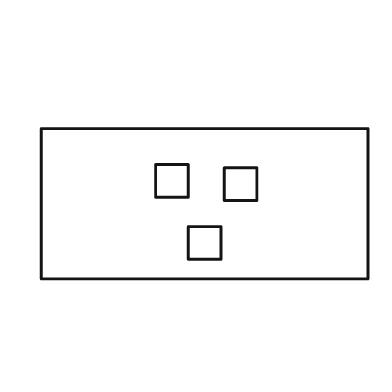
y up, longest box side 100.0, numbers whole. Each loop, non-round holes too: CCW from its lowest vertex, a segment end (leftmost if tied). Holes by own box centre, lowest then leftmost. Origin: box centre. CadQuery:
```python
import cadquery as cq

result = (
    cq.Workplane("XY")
    .moveTo(-50.0, -23.0)
    .lineTo(50.0, -23.0)
    .lineTo(50.0, 23.0)
    .lineTo(-50.0, 23.0)
    .close()
    .moveTo(-5.0, -17.0)
    .lineTo(5.0, -17.0)
    .lineTo(5.0, -7.0)
    .lineTo(-5.0, -7.0)
    .close()
    .moveTo(6.0, 1.0)
    .lineTo(16.0, 1.0)
    .lineTo(16.0, 11.0)
    .lineTo(6.0, 11.0)
    .close()
    .moveTo(-15.0, 2.0)
    .lineTo(-5.0, 2.0)
    .lineTo(-5.0, 12.0)
    .lineTo(-15.0, 12.0)
    .close()
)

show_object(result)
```